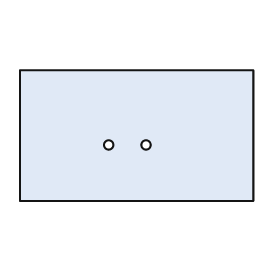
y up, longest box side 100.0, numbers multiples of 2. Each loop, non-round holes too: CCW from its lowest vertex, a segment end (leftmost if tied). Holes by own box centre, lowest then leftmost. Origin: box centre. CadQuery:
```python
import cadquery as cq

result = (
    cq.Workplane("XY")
    .moveTo(-50.0, -28.0)
    .lineTo(50.0, -28.0)
    .lineTo(50.0, 28.0)
    .lineTo(-50.0, 28.0)
    .close()
    .moveTo(-12.0, -4.0)
    .circle(2.0)
    .moveTo(4.0, -4.0)
    .circle(2.0)
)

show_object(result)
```